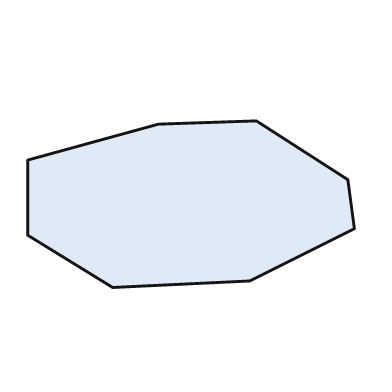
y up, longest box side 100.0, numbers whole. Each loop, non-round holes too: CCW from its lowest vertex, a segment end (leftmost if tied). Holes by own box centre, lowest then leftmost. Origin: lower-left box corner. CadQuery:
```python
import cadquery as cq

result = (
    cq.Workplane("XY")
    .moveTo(26.0, 0.0)
    .lineTo(68.0, 2.0)
    .lineTo(100.0, 18.0)
    .lineTo(98.0, 33.0)
    .lineTo(70.0, 51.0)
    .lineTo(40.0, 50.0)
    .lineTo(0.0, 39.0)
    .lineTo(0.0, 16.0)
    .close()
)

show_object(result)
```